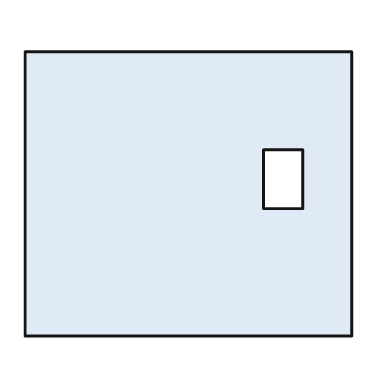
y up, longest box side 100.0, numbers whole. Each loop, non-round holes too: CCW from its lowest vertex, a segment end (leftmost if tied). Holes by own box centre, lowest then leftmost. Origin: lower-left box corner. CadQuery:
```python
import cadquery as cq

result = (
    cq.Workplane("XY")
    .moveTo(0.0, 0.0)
    .lineTo(100.0, 0.0)
    .lineTo(100.0, 87.0)
    .lineTo(0.0, 87.0)
    .close()
    .moveTo(73.0, 39.0)
    .lineTo(85.0, 39.0)
    .lineTo(85.0, 57.0)
    .lineTo(73.0, 57.0)
    .close()
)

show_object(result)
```